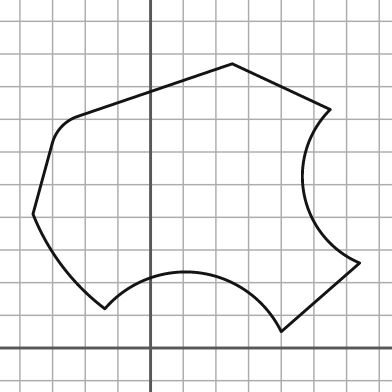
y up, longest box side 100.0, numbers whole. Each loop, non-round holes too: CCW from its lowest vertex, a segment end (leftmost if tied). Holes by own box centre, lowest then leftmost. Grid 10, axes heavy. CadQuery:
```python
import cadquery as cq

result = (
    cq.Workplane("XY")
    .moveTo(40.0, 5.0)
    .lineTo(64.0, 26.0)
    .threePointArc((47.0, 47.0), (55.0, 73.0))
    .lineTo(25.0, 87.0)
    .lineTo(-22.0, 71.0)
    .threePointArc((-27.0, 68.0), (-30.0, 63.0))
    .lineTo(-36.0, 41.0)
    .threePointArc((-27.0, 25.0), (-14.0, 12.0))
    .threePointArc((15.0, 23.0), (40.0, 5.0))
    .close()
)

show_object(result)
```